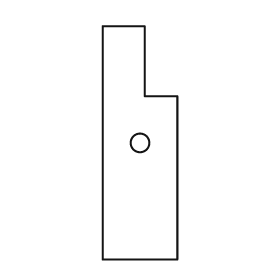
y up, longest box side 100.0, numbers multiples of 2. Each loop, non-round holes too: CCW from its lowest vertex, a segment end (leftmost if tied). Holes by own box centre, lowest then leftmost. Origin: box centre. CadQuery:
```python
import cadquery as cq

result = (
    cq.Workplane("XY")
    .moveTo(-16.0, -50.0)
    .lineTo(16.0, -50.0)
    .lineTo(16.0, 20.0)
    .lineTo(2.0, 20.0)
    .lineTo(2.0, 50.0)
    .lineTo(-16.0, 50.0)
    .close()
    .moveTo(0.0, 0.0)
    .circle(4.0)
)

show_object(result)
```